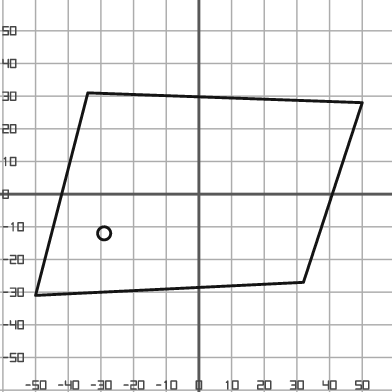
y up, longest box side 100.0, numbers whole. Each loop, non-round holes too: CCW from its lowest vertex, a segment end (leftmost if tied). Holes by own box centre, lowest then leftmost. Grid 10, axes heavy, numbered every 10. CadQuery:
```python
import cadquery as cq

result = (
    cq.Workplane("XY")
    .moveTo(-50.0, -31.0)
    .lineTo(32.0, -27.0)
    .lineTo(50.0, 28.0)
    .lineTo(-34.0, 31.0)
    .close()
    .moveTo(-29.0, -12.0)
    .circle(2.0)
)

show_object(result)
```